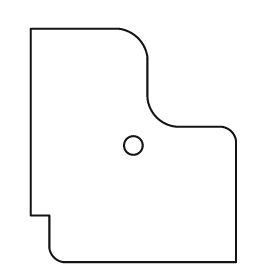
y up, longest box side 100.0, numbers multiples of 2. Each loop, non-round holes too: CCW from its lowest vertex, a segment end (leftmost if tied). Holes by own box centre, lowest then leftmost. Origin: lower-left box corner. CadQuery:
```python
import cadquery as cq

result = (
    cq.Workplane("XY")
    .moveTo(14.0, 0.0)
    .lineTo(88.0, 0.0)
    .lineTo(88.0, 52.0)
    .threePointArc((86.0, 56.0), (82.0, 58.0))
    .lineTo(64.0, 58.0)
    .threePointArc((54.0, 62.0), (50.0, 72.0))
    .lineTo(50.0, 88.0)
    .threePointArc((46.0, 96.0), (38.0, 100.0))
    .lineTo(0.0, 100.0)
    .lineTo(0.0, 20.0)
    .lineTo(8.0, 20.0)
    .lineTo(8.0, 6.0)
    .threePointArc((10.0, 2.0), (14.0, 0.0))
    .close()
    .moveTo(44.0, 50.0)
    .circle(4.0)
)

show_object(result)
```